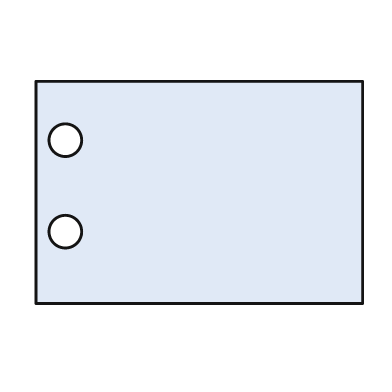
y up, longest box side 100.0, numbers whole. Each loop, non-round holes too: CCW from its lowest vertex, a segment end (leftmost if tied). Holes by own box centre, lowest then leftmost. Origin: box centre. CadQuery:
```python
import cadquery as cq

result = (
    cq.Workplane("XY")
    .moveTo(-50.0, -34.0)
    .lineTo(50.0, -34.0)
    .lineTo(50.0, 34.0)
    .lineTo(-50.0, 34.0)
    .close()
    .moveTo(-41.0, -12.0)
    .circle(5.0)
    .moveTo(-41.0, 16.0)
    .circle(5.0)
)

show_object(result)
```